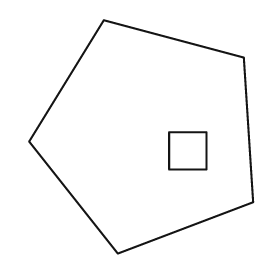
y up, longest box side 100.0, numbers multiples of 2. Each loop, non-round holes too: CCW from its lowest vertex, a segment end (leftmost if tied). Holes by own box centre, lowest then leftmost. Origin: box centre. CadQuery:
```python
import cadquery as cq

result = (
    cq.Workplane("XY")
    .moveTo(-10.0, -50.0)
    .lineTo(48.0, -28.0)
    .lineTo(44.0, 34.0)
    .lineTo(-16.0, 50.0)
    .lineTo(-48.0, -2.0)
    .close()
    .moveTo(12.0, -14.0)
    .lineTo(28.0, -14.0)
    .lineTo(28.0, 2.0)
    .lineTo(12.0, 2.0)
    .close()
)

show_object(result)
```